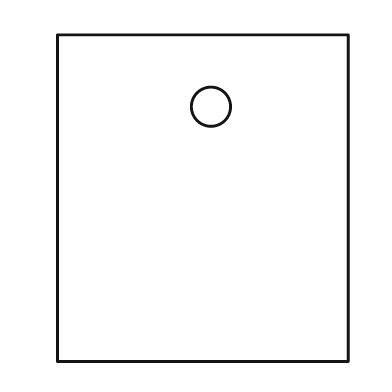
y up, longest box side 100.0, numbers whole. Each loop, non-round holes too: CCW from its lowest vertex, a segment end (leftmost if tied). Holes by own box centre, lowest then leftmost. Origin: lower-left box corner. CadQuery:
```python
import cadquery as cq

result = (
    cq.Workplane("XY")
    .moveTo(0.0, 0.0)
    .lineTo(89.0, 0.0)
    .lineTo(89.0, 100.0)
    .lineTo(0.0, 100.0)
    .close()
    .moveTo(47.0, 78.0)
    .circle(6.0)
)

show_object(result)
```